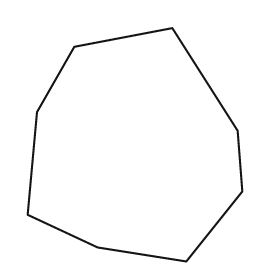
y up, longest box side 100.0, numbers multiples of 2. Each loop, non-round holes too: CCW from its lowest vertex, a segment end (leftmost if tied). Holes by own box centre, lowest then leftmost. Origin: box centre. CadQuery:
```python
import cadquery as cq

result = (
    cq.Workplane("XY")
    .moveTo(22.0, -50.0)
    .lineTo(46.0, -20.0)
    .lineTo(44.0, 6.0)
    .lineTo(16.0, 50.0)
    .lineTo(-26.0, 42.0)
    .lineTo(-42.0, 14.0)
    .lineTo(-46.0, -30.0)
    .lineTo(-16.0, -44.0)
    .close()
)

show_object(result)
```